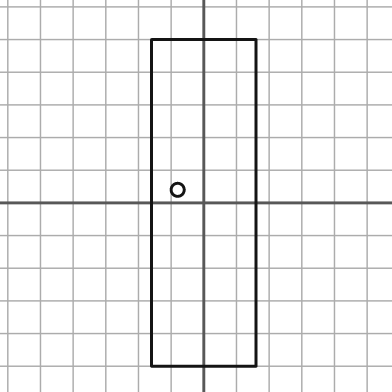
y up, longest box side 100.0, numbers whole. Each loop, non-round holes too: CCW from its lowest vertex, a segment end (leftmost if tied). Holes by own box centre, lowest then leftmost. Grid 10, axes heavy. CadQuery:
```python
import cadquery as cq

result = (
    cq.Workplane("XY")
    .moveTo(-16.0, -50.0)
    .lineTo(16.0, -50.0)
    .lineTo(16.0, 50.0)
    .lineTo(-16.0, 50.0)
    .close()
    .moveTo(-8.0, 4.0)
    .circle(2.0)
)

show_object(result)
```